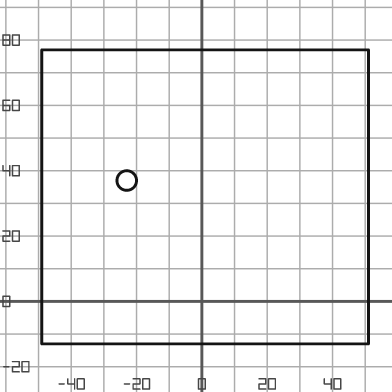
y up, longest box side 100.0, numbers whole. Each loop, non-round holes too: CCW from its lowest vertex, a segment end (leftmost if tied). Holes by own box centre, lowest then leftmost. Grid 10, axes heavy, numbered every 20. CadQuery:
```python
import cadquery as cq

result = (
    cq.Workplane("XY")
    .moveTo(-49.0, -13.0)
    .lineTo(51.0, -13.0)
    .lineTo(51.0, 77.0)
    .lineTo(-49.0, 77.0)
    .close()
    .moveTo(-23.0, 37.0)
    .circle(3.0)
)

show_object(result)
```